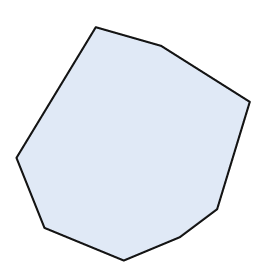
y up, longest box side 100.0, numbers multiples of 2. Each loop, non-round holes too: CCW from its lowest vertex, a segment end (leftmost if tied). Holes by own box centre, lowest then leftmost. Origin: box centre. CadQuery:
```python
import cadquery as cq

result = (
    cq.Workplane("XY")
    .moveTo(-4.0, -50.0)
    .lineTo(20.0, -40.0)
    .lineTo(36.0, -28.0)
    .lineTo(50.0, 18.0)
    .lineTo(12.0, 42.0)
    .lineTo(-16.0, 50.0)
    .lineTo(-50.0, -6.0)
    .lineTo(-38.0, -36.0)
    .close()
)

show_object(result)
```